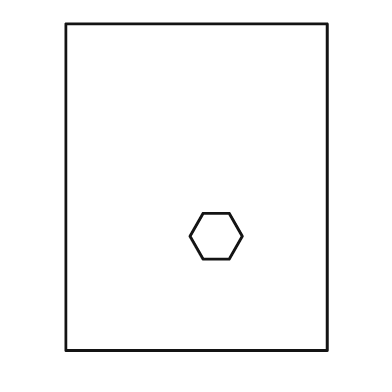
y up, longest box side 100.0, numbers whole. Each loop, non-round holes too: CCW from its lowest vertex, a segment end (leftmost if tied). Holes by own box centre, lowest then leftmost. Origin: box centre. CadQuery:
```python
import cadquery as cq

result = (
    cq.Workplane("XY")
    .moveTo(-40.0, -50.0)
    .lineTo(40.0, -50.0)
    .lineTo(40.0, 50.0)
    .lineTo(-40.0, 50.0)
    .close()
    .moveTo(2.0, -22.0)
    .lineTo(10.0, -22.0)
    .lineTo(14.0, -15.0)
    .lineTo(10.0, -8.0)
    .lineTo(2.0, -8.0)
    .lineTo(-2.0, -15.0)
    .close()
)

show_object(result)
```